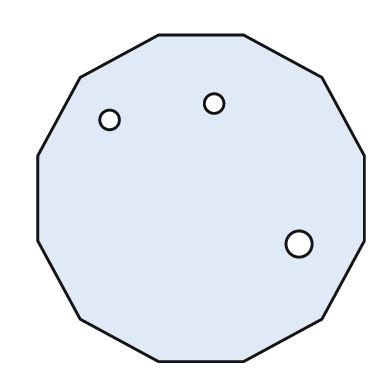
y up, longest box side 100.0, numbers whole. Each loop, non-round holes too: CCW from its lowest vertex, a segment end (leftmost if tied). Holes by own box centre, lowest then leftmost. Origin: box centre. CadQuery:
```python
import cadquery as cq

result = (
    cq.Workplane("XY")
    .moveTo(-13.0, -50.0)
    .lineTo(13.0, -50.0)
    .lineTo(37.0, -37.0)
    .lineTo(50.0, -13.0)
    .lineTo(50.0, 13.0)
    .lineTo(37.0, 37.0)
    .lineTo(13.0, 50.0)
    .lineTo(-13.0, 50.0)
    .lineTo(-37.0, 37.0)
    .lineTo(-50.0, 13.0)
    .lineTo(-50.0, -13.0)
    .lineTo(-37.0, -37.0)
    .close()
    .moveTo(30.0, -14.0)
    .circle(4.0)
    .moveTo(-28.0, 24.0)
    .circle(3.0)
    .moveTo(4.0, 29.0)
    .circle(3.0)
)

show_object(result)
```